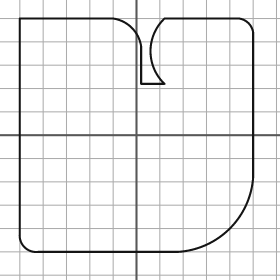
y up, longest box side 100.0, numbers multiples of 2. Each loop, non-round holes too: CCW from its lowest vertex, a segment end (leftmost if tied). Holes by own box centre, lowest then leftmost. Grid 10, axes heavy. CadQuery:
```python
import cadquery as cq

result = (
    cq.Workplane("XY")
    .moveTo(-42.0, -50.0)
    .lineTo(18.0, -50.0)
    .threePointArc((40.0, -40.0), (50.0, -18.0))
    .lineTo(50.0, 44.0)
    .threePointArc((48.0, 48.0), (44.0, 50.0))
    .lineTo(12.0, 50.0)
    .threePointArc((6.0, 36.0), (12.0, 22.0))
    .lineTo(2.0, 22.0)
    .lineTo(2.0, 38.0)
    .threePointArc((-2.0, 46.0), (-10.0, 50.0))
    .lineTo(-50.0, 50.0)
    .lineTo(-50.0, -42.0)
    .threePointArc((-48.0, -48.0), (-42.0, -50.0))
    .close()
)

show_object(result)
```